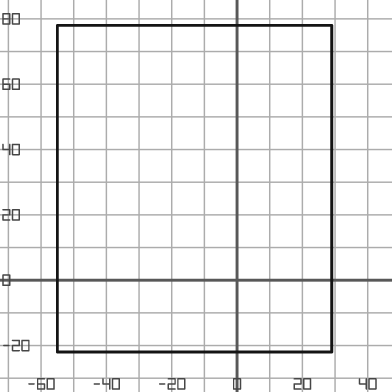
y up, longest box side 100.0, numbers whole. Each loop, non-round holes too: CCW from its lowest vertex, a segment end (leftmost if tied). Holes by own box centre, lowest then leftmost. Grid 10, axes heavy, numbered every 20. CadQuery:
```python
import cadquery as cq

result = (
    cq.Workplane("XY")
    .moveTo(-55.0, -22.0)
    .lineTo(29.0, -22.0)
    .lineTo(29.0, 78.0)
    .lineTo(-55.0, 78.0)
    .close()
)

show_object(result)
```